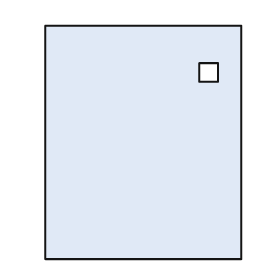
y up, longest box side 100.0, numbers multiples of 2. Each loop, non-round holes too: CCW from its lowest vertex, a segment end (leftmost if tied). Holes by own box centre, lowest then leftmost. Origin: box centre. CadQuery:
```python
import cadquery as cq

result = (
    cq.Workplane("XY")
    .moveTo(-42.0, -50.0)
    .lineTo(42.0, -50.0)
    .lineTo(42.0, 50.0)
    .lineTo(-42.0, 50.0)
    .close()
    .moveTo(24.0, 26.0)
    .lineTo(32.0, 26.0)
    .lineTo(32.0, 34.0)
    .lineTo(24.0, 34.0)
    .close()
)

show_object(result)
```